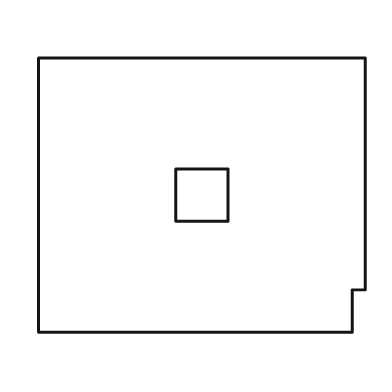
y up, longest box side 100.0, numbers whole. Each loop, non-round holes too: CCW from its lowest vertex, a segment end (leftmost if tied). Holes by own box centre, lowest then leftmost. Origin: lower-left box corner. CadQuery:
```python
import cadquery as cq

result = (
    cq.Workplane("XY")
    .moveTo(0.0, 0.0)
    .lineTo(96.0, 0.0)
    .lineTo(96.0, 13.0)
    .lineTo(100.0, 13.0)
    .lineTo(100.0, 84.0)
    .lineTo(0.0, 84.0)
    .close()
    .moveTo(42.0, 34.0)
    .lineTo(58.0, 34.0)
    .lineTo(58.0, 50.0)
    .lineTo(42.0, 50.0)
    .close()
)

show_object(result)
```